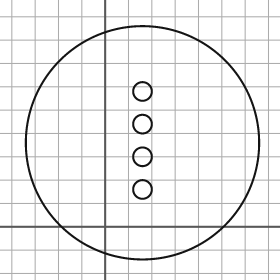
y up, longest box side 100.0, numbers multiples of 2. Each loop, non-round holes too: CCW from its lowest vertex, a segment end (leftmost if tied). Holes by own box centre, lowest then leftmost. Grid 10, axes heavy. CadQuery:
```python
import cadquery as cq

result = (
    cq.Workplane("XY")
    .moveTo(16.0, 36.0)
    .circle(50.0)
    .moveTo(16.0, 16.0)
    .circle(4.0)
    .moveTo(16.0, 30.0)
    .circle(4.0)
    .moveTo(16.0, 44.0)
    .circle(4.0)
    .moveTo(16.0, 58.0)
    .circle(4.0)
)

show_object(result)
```